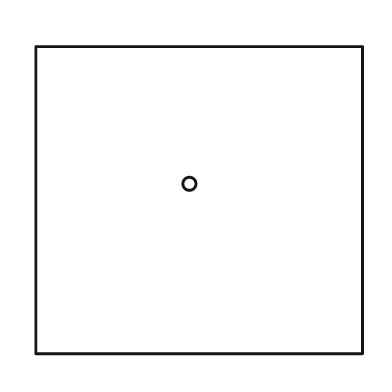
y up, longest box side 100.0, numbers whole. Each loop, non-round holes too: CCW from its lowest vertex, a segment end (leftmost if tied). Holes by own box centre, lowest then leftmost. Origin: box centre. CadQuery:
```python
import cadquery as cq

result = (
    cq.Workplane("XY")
    .moveTo(-50.0, -47.0)
    .lineTo(50.0, -47.0)
    .lineTo(50.0, 47.0)
    .lineTo(-50.0, 47.0)
    .close()
    .moveTo(-3.0, 5.0)
    .circle(2.0)
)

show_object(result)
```